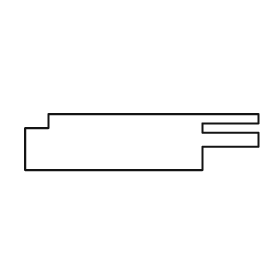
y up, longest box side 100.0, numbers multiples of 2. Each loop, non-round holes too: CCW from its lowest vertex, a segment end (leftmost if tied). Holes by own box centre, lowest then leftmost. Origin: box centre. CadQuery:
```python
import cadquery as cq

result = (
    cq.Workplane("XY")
    .moveTo(-50.0, -12.0)
    .lineTo(26.0, -12.0)
    .lineTo(26.0, -2.0)
    .lineTo(50.0, -2.0)
    .lineTo(50.0, 4.0)
    .lineTo(26.0, 4.0)
    .lineTo(26.0, 8.0)
    .lineTo(50.0, 8.0)
    .lineTo(50.0, 12.0)
    .lineTo(-40.0, 12.0)
    .lineTo(-40.0, 6.0)
    .lineTo(-50.0, 6.0)
    .close()
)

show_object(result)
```